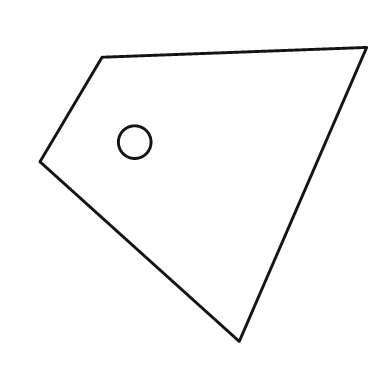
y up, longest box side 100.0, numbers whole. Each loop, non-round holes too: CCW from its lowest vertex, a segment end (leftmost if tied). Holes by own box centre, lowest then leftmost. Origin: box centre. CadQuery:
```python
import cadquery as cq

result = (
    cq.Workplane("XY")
    .moveTo(11.0, -45.0)
    .lineTo(50.0, 45.0)
    .lineTo(-31.0, 42.0)
    .lineTo(-50.0, 10.0)
    .close()
    .moveTo(-21.0, 16.0)
    .circle(5.0)
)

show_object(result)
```